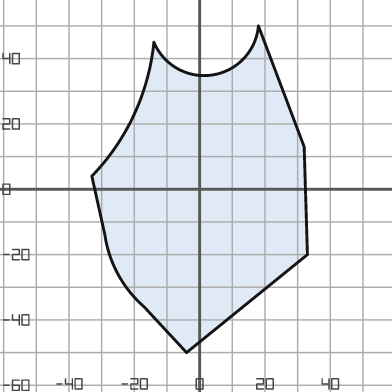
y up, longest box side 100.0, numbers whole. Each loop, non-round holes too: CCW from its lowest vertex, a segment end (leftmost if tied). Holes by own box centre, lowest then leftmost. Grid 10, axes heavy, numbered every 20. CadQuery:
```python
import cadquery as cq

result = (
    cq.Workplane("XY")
    .moveTo(-4.0, -50.0)
    .lineTo(33.0, -20.0)
    .lineTo(32.0, 13.0)
    .lineTo(18.0, 50.0)
    .threePointArc((4.0, 35.0), (-14.0, 45.0))
    .threePointArc((-20.0, 23.0), (-33.0, 4.0))
    .lineTo(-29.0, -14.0)
    .threePointArc((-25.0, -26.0), (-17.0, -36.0))
    .close()
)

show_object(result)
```